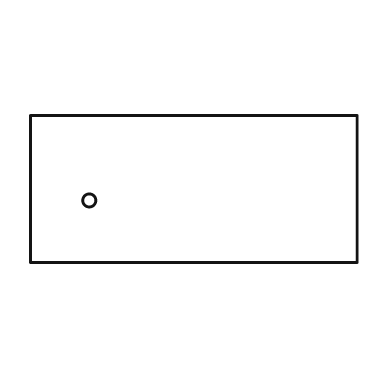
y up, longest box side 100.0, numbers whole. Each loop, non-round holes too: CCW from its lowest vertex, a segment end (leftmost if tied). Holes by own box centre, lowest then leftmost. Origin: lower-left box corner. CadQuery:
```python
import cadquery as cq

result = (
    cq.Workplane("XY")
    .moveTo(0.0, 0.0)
    .lineTo(100.0, 0.0)
    .lineTo(100.0, 45.0)
    .lineTo(0.0, 45.0)
    .close()
    .moveTo(18.0, 19.0)
    .circle(2.0)
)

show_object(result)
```